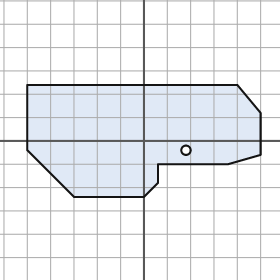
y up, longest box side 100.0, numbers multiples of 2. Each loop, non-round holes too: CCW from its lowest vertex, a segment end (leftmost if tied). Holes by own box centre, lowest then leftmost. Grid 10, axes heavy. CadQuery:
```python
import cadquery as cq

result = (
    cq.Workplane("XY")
    .moveTo(-30.0, -24.0)
    .lineTo(0.0, -24.0)
    .lineTo(6.0, -18.0)
    .lineTo(6.0, -10.0)
    .lineTo(36.0, -10.0)
    .lineTo(50.0, -6.0)
    .lineTo(50.0, 12.0)
    .lineTo(40.0, 24.0)
    .lineTo(-50.0, 24.0)
    .lineTo(-50.0, -4.0)
    .close()
    .moveTo(18.0, -4.0)
    .circle(2.0)
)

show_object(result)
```